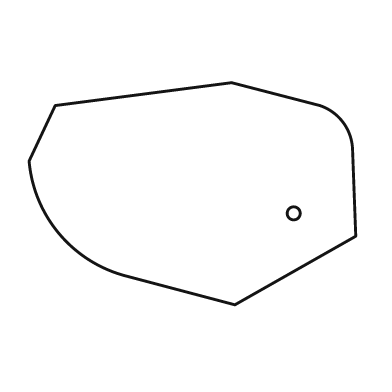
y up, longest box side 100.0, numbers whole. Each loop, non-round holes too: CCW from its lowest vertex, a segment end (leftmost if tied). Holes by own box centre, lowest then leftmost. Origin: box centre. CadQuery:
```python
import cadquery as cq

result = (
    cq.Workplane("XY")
    .moveTo(13.0, -34.0)
    .lineTo(50.0, -13.0)
    .lineTo(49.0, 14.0)
    .threePointArc((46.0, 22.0), (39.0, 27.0))
    .lineTo(12.0, 34.0)
    .lineTo(-42.0, 27.0)
    .lineTo(-50.0, 10.0)
    .threePointArc((-41.0, -12.0), (-21.0, -25.0))
    .close()
    .moveTo(31.0, -6.0)
    .circle(2.0)
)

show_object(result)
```